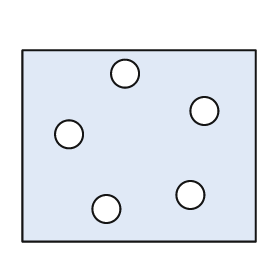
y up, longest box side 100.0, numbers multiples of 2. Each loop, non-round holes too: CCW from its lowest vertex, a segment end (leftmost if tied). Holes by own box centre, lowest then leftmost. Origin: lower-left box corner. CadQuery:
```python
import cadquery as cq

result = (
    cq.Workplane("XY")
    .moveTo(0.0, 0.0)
    .lineTo(100.0, 0.0)
    .lineTo(100.0, 82.0)
    .lineTo(0.0, 82.0)
    .close()
    .moveTo(36.0, 14.0)
    .circle(6.0)
    .moveTo(72.0, 20.0)
    .circle(6.0)
    .moveTo(20.0, 46.0)
    .circle(6.0)
    .moveTo(78.0, 56.0)
    .circle(6.0)
    .moveTo(44.0, 72.0)
    .circle(6.0)
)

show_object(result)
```